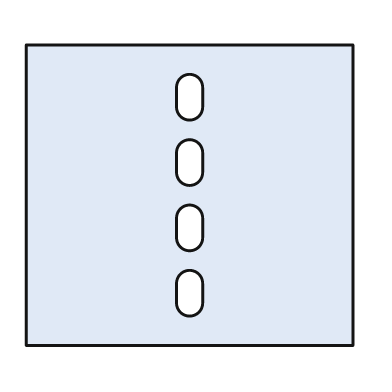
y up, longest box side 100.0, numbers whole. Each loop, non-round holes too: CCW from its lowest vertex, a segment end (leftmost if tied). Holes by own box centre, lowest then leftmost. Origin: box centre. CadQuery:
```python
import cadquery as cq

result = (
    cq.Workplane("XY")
    .moveTo(-50.0, -46.0)
    .lineTo(50.0, -46.0)
    .lineTo(50.0, 46.0)
    .lineTo(-50.0, 46.0)
    .close()
    .moveTo(-4.0, -33.0)
    .threePointArc((0.0, -37.0), (4.0, -33.0))
    .lineTo(4.0, -27.0)
    .threePointArc((0.0, -23.0), (-4.0, -27.0))
    .close()
    .moveTo(-4.0, -13.0)
    .threePointArc((0.0, -17.0), (4.0, -13.0))
    .lineTo(4.0, -7.0)
    .threePointArc((0.0, -3.0), (-4.0, -7.0))
    .close()
    .moveTo(-4.0, 7.0)
    .threePointArc((0.0, 3.0), (4.0, 7.0))
    .lineTo(4.0, 13.0)
    .threePointArc((0.0, 17.0), (-4.0, 13.0))
    .close()
    .moveTo(-4.0, 27.0)
    .threePointArc((0.0, 23.0), (4.0, 27.0))
    .lineTo(4.0, 33.0)
    .threePointArc((0.0, 37.0), (-4.0, 33.0))
    .close()
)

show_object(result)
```